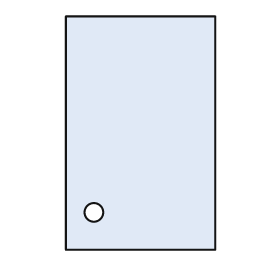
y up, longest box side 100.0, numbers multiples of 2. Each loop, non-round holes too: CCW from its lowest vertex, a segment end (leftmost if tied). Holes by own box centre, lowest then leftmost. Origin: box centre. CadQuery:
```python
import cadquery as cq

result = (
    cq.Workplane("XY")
    .moveTo(-32.0, -50.0)
    .lineTo(32.0, -50.0)
    .lineTo(32.0, 50.0)
    .lineTo(-32.0, 50.0)
    .close()
    .moveTo(-20.0, -34.0)
    .circle(4.0)
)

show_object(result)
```